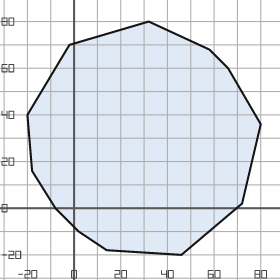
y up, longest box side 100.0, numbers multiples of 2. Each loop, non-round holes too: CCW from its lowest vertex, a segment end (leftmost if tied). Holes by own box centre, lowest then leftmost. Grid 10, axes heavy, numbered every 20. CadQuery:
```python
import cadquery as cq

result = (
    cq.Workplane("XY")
    .moveTo(46.0, -20.0)
    .lineTo(72.0, 2.0)
    .lineTo(80.0, 36.0)
    .lineTo(66.0, 60.0)
    .lineTo(58.0, 68.0)
    .lineTo(32.0, 80.0)
    .lineTo(-2.0, 70.0)
    .lineTo(-20.0, 40.0)
    .lineTo(-18.0, 16.0)
    .lineTo(-8.0, 0.0)
    .lineTo(2.0, -10.0)
    .lineTo(14.0, -18.0)
    .close()
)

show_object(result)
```